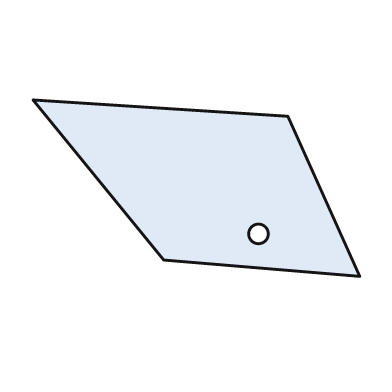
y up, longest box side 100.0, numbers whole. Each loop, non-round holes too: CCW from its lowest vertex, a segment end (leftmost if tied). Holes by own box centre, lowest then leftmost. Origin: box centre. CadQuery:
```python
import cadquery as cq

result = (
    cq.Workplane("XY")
    .moveTo(50.0, -27.0)
    .lineTo(28.0, 22.0)
    .lineTo(-50.0, 27.0)
    .lineTo(-10.0, -22.0)
    .close()
    .moveTo(19.0, -14.0)
    .circle(3.0)
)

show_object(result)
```